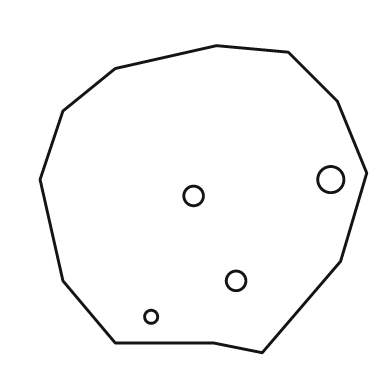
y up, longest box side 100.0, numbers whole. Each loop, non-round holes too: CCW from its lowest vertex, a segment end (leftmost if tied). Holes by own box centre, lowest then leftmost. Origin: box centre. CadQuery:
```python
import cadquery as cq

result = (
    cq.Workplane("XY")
    .moveTo(18.0, -47.0)
    .lineTo(42.0, -19.0)
    .lineTo(50.0, 8.0)
    .lineTo(41.0, 30.0)
    .lineTo(26.0, 45.0)
    .lineTo(4.0, 47.0)
    .lineTo(-27.0, 40.0)
    .lineTo(-43.0, 27.0)
    .lineTo(-50.0, 6.0)
    .lineTo(-43.0, -25.0)
    .lineTo(-27.0, -44.0)
    .lineTo(3.0, -44.0)
    .close()
    .moveTo(-16.0, -36.0)
    .circle(2.0)
    .moveTo(10.0, -25.0)
    .circle(3.0)
    .moveTo(-3.0, 1.0)
    .circle(3.0)
    .moveTo(39.0, 6.0)
    .circle(4.0)
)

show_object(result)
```